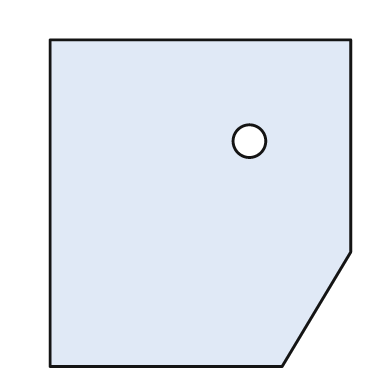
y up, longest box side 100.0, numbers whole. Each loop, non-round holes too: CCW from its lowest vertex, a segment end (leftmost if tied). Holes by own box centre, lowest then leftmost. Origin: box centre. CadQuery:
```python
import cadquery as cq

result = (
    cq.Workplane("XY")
    .moveTo(-46.0, -50.0)
    .lineTo(25.0, -50.0)
    .lineTo(46.0, -15.0)
    .lineTo(46.0, 50.0)
    .lineTo(-46.0, 50.0)
    .close()
    .moveTo(15.0, 19.0)
    .circle(5.0)
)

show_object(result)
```